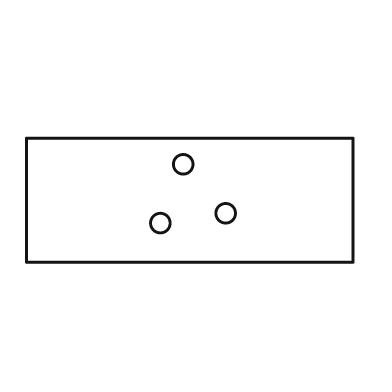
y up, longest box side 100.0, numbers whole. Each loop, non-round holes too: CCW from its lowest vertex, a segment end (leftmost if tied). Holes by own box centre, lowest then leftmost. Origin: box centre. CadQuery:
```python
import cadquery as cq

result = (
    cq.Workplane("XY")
    .moveTo(-50.0, -19.0)
    .lineTo(50.0, -19.0)
    .lineTo(50.0, 19.0)
    .lineTo(-50.0, 19.0)
    .close()
    .moveTo(-9.0, -7.0)
    .circle(3.0)
    .moveTo(11.0, -4.0)
    .circle(3.0)
    .moveTo(-2.0, 11.0)
    .circle(3.0)
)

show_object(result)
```